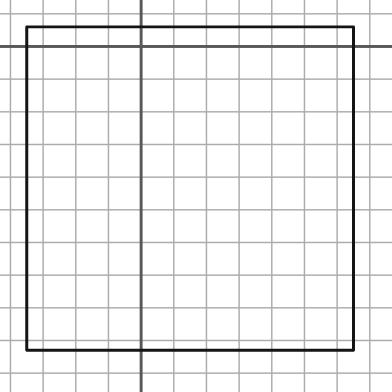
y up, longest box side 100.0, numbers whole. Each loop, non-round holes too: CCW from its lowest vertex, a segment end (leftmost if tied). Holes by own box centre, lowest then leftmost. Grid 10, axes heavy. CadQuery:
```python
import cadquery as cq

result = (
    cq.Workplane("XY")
    .moveTo(-35.0, -93.0)
    .lineTo(65.0, -93.0)
    .lineTo(65.0, 6.0)
    .lineTo(-35.0, 6.0)
    .close()
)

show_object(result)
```